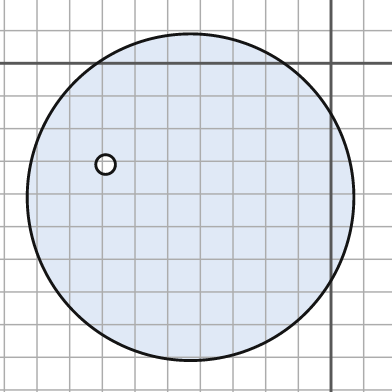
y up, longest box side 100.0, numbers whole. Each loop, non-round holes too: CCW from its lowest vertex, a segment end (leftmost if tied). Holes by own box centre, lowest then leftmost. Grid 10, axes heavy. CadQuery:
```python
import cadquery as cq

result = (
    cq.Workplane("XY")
    .moveTo(-43.0, -41.0)
    .circle(50.0)
    .moveTo(-69.0, -31.0)
    .circle(3.0)
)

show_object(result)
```